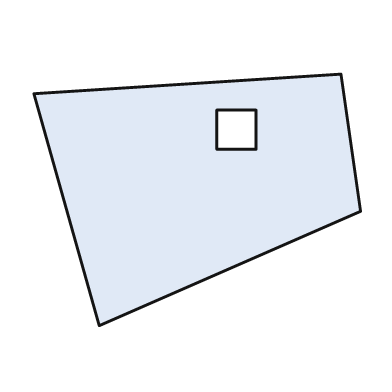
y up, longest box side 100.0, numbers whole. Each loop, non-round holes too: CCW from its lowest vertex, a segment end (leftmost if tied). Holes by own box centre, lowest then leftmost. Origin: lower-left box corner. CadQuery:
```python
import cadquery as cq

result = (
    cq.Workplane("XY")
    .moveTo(20.0, 0.0)
    .lineTo(100.0, 35.0)
    .lineTo(94.0, 77.0)
    .lineTo(0.0, 71.0)
    .close()
    .moveTo(56.0, 54.0)
    .lineTo(68.0, 54.0)
    .lineTo(68.0, 66.0)
    .lineTo(56.0, 66.0)
    .close()
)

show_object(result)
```